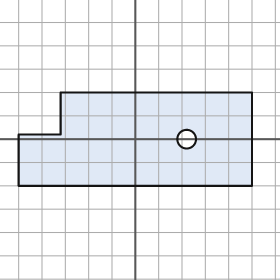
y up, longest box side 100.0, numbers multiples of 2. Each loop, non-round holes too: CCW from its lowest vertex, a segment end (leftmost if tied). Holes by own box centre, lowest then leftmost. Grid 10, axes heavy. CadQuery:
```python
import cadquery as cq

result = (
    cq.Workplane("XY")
    .moveTo(-50.0, -20.0)
    .lineTo(50.0, -20.0)
    .lineTo(50.0, 20.0)
    .lineTo(-32.0, 20.0)
    .lineTo(-32.0, 2.0)
    .lineTo(-50.0, 2.0)
    .close()
    .moveTo(22.0, 0.0)
    .circle(4.0)
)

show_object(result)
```